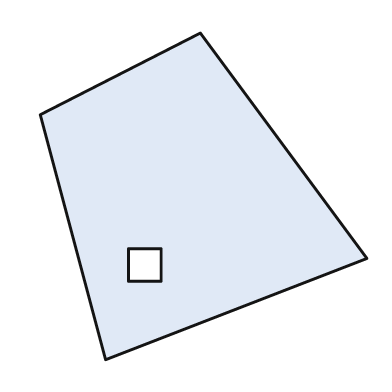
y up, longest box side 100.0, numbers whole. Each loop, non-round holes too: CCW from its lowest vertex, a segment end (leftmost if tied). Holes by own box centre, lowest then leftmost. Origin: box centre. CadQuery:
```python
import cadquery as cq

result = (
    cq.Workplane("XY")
    .moveTo(-30.0, -50.0)
    .lineTo(50.0, -19.0)
    .lineTo(-1.0, 50.0)
    .lineTo(-50.0, 25.0)
    .close()
    .moveTo(-23.0, -26.0)
    .lineTo(-13.0, -26.0)
    .lineTo(-13.0, -16.0)
    .lineTo(-23.0, -16.0)
    .close()
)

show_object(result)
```